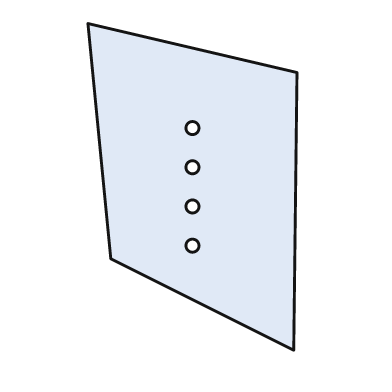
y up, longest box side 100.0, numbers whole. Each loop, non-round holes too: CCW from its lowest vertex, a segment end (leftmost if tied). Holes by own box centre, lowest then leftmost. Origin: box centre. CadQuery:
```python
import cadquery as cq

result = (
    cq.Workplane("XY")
    .moveTo(31.0, -50.0)
    .lineTo(32.0, 35.0)
    .lineTo(-32.0, 50.0)
    .lineTo(-25.0, -22.0)
    .close()
    .moveTo(0.0, -18.0)
    .circle(2.0)
    .moveTo(0.0, -6.0)
    .circle(2.0)
    .moveTo(0.0, 6.0)
    .circle(2.0)
    .moveTo(0.0, 18.0)
    .circle(2.0)
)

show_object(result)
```